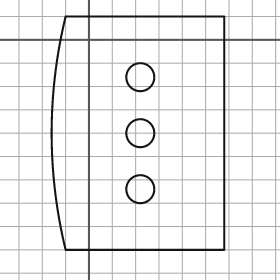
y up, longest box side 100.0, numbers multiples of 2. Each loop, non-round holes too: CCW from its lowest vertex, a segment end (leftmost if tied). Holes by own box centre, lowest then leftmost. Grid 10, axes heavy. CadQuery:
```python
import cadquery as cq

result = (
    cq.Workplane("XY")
    .moveTo(-10.0, -90.0)
    .lineTo(58.0, -90.0)
    .lineTo(58.0, 10.0)
    .lineTo(-10.0, 10.0)
    .threePointArc((-16.0, -40.0), (-10.0, -90.0))
    .close()
    .moveTo(22.0, -64.0)
    .circle(6.0)
    .moveTo(22.0, -40.0)
    .circle(6.0)
    .moveTo(22.0, -16.0)
    .circle(6.0)
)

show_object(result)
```